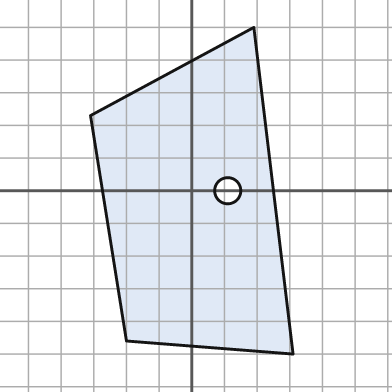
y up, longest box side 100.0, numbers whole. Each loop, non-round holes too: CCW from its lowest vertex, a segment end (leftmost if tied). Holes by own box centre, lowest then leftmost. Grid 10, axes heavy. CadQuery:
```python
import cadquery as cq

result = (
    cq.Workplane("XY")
    .moveTo(31.0, -50.0)
    .lineTo(19.0, 50.0)
    .lineTo(-31.0, 23.0)
    .lineTo(-20.0, -46.0)
    .close()
    .moveTo(11.0, 0.0)
    .circle(4.0)
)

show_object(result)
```